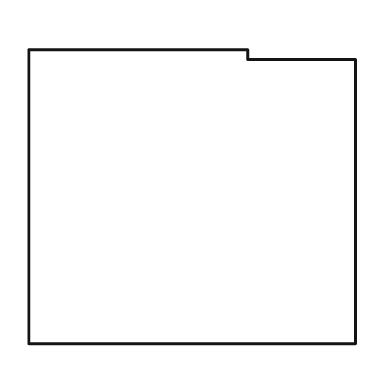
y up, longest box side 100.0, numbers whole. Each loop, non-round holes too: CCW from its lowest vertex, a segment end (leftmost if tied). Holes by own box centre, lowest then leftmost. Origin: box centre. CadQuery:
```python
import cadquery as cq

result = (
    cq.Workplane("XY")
    .moveTo(-50.0, -45.0)
    .lineTo(50.0, -45.0)
    .lineTo(50.0, 42.0)
    .lineTo(17.0, 42.0)
    .lineTo(17.0, 45.0)
    .lineTo(-50.0, 45.0)
    .close()
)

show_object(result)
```